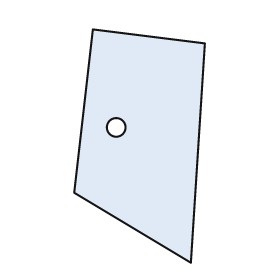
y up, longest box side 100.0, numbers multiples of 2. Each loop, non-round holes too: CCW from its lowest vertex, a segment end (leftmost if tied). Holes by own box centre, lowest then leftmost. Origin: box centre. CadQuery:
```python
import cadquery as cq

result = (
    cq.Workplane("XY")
    .moveTo(22.0, -50.0)
    .lineTo(28.0, 44.0)
    .lineTo(-20.0, 50.0)
    .lineTo(-28.0, -20.0)
    .close()
    .moveTo(-10.0, 8.0)
    .circle(4.0)
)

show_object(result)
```